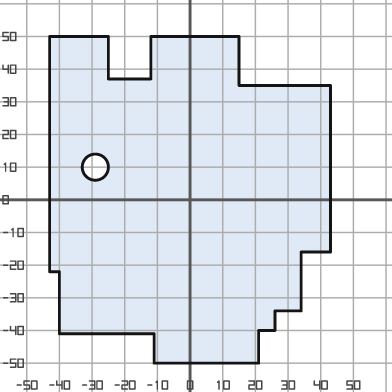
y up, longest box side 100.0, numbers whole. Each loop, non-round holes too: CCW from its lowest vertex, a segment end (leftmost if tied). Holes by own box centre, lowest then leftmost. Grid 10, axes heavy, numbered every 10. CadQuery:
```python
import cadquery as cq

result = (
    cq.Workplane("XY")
    .moveTo(-11.0, -50.0)
    .lineTo(21.0, -50.0)
    .lineTo(21.0, -40.0)
    .lineTo(26.0, -40.0)
    .lineTo(26.0, -34.0)
    .lineTo(34.0, -34.0)
    .lineTo(34.0, -16.0)
    .lineTo(43.0, -16.0)
    .lineTo(43.0, 35.0)
    .lineTo(15.0, 35.0)
    .lineTo(15.0, 50.0)
    .lineTo(-12.0, 50.0)
    .lineTo(-12.0, 37.0)
    .lineTo(-25.0, 37.0)
    .lineTo(-25.0, 50.0)
    .lineTo(-43.0, 50.0)
    .lineTo(-43.0, -22.0)
    .lineTo(-40.0, -22.0)
    .lineTo(-40.0, -41.0)
    .lineTo(-11.0, -41.0)
    .close()
    .moveTo(-29.0, 10.0)
    .circle(4.0)
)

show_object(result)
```